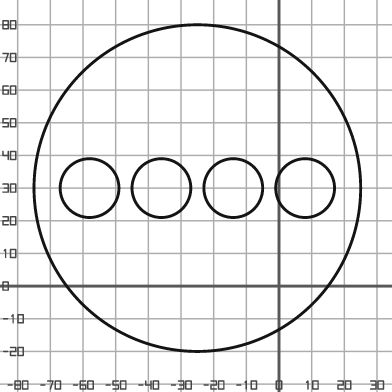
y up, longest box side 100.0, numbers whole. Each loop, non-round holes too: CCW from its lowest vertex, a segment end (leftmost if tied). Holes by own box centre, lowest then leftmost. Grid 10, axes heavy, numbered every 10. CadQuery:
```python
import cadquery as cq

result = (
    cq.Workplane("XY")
    .moveTo(-25.0, 30.0)
    .circle(50.0)
    .moveTo(-58.0, 30.0)
    .circle(9.0)
    .moveTo(-36.0, 30.0)
    .circle(9.0)
    .moveTo(-14.0, 30.0)
    .circle(9.0)
    .moveTo(8.0, 30.0)
    .circle(9.0)
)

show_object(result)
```